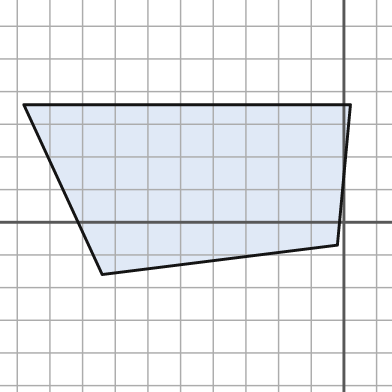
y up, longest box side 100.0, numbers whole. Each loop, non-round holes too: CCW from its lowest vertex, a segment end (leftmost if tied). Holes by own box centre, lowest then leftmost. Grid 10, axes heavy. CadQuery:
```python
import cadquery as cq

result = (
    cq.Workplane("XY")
    .moveTo(-74.0, -16.0)
    .lineTo(-2.0, -7.0)
    .lineTo(2.0, 36.0)
    .lineTo(-98.0, 36.0)
    .close()
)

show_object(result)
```